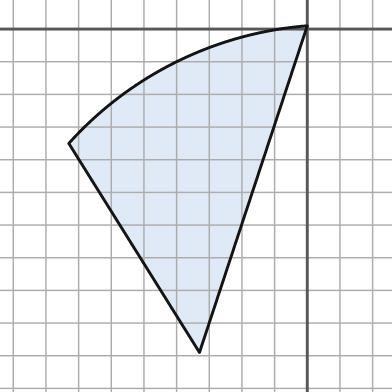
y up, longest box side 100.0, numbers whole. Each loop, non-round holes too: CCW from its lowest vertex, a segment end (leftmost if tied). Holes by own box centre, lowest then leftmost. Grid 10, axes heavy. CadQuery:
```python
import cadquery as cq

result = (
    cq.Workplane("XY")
    .moveTo(-33.0, -99.0)
    .lineTo(0.0, 1.0)
    .threePointArc((-40.0, -10.0), (-73.0, -35.0))
    .close()
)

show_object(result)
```